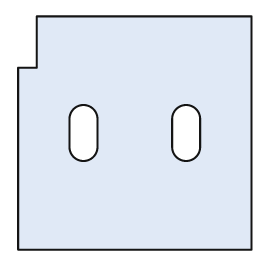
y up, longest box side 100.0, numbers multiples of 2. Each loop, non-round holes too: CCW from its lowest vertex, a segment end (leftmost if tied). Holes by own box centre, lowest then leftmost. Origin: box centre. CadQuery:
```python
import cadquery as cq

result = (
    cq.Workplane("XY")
    .moveTo(-50.0, -50.0)
    .lineTo(50.0, -50.0)
    .lineTo(50.0, 50.0)
    .lineTo(-42.0, 50.0)
    .lineTo(-42.0, 28.0)
    .lineTo(-50.0, 28.0)
    .close()
    .moveTo(-28.0, -6.0)
    .threePointArc((-22.0, -12.0), (-16.0, -6.0))
    .lineTo(-16.0, 6.0)
    .threePointArc((-22.0, 12.0), (-28.0, 6.0))
    .close()
    .moveTo(16.0, -6.0)
    .threePointArc((22.0, -12.0), (28.0, -6.0))
    .lineTo(28.0, 6.0)
    .threePointArc((22.0, 12.0), (16.0, 6.0))
    .close()
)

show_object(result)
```